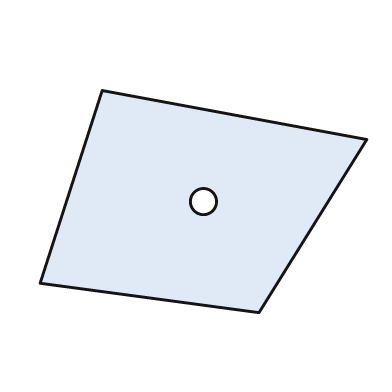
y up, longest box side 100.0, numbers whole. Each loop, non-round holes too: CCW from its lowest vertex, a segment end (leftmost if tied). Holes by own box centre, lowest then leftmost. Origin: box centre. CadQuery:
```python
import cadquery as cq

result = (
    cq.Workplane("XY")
    .moveTo(17.0, -34.0)
    .lineTo(50.0, 19.0)
    .lineTo(-31.0, 34.0)
    .lineTo(-50.0, -25.0)
    .close()
    .moveTo(0.0, 0.0)
    .circle(4.0)
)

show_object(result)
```